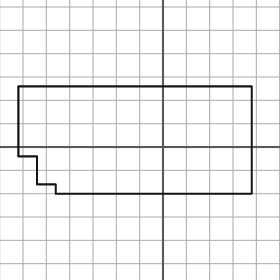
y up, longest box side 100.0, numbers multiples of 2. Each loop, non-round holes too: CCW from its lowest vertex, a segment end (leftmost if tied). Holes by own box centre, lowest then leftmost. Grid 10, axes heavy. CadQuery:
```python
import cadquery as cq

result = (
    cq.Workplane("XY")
    .moveTo(-46.0, -20.0)
    .lineTo(38.0, -20.0)
    .lineTo(38.0, 26.0)
    .lineTo(-62.0, 26.0)
    .lineTo(-62.0, -4.0)
    .lineTo(-54.0, -4.0)
    .lineTo(-54.0, -16.0)
    .lineTo(-46.0, -16.0)
    .close()
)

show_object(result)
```